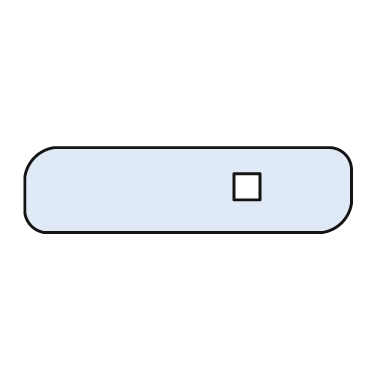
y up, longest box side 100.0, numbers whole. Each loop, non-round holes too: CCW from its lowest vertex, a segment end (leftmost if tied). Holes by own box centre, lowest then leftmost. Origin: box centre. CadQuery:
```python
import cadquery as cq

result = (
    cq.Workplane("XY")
    .moveTo(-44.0, -13.0)
    .lineTo(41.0, -13.0)
    .threePointArc((47.0, -10.0), (50.0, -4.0))
    .lineTo(50.0, 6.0)
    .threePointArc((48.0, 11.0), (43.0, 13.0))
    .lineTo(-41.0, 13.0)
    .threePointArc((-47.0, 10.0), (-50.0, 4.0))
    .lineTo(-50.0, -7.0)
    .threePointArc((-48.0, -11.0), (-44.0, -13.0))
    .close()
    .moveTo(14.0, -3.0)
    .lineTo(22.0, -3.0)
    .lineTo(22.0, 5.0)
    .lineTo(14.0, 5.0)
    .close()
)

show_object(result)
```